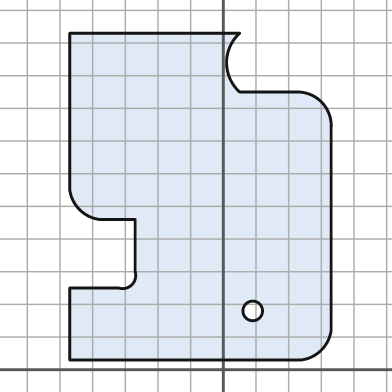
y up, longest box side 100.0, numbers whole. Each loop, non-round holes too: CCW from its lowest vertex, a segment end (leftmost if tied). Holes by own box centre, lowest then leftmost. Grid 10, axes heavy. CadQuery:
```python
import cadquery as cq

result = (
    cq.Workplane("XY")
    .moveTo(-47.0, 3.0)
    .lineTo(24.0, 3.0)
    .threePointArc((30.0, 6.0), (33.0, 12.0))
    .lineTo(33.0, 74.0)
    .threePointArc((30.0, 82.0), (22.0, 85.0))
    .lineTo(5.0, 85.0)
    .threePointArc((1.0, 94.0), (5.0, 103.0))
    .lineTo(-47.0, 103.0)
    .lineTo(-47.0, 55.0)
    .threePointArc((-44.0, 49.0), (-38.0, 46.0))
    .lineTo(-27.0, 46.0)
    .lineTo(-27.0, 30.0)
    .threePointArc((-28.0, 26.0), (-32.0, 25.0))
    .lineTo(-47.0, 25.0)
    .close()
    .moveTo(9.0, 18.0)
    .circle(3.0)
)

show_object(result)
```